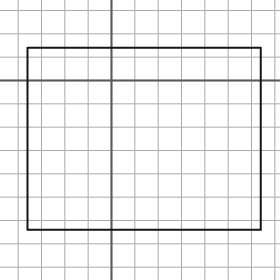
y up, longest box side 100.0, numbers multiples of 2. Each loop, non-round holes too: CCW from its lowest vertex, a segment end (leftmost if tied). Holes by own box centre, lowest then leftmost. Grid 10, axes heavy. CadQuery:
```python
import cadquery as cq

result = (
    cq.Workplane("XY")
    .moveTo(-36.0, -64.0)
    .lineTo(64.0, -64.0)
    .lineTo(64.0, 14.0)
    .lineTo(-36.0, 14.0)
    .close()
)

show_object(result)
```